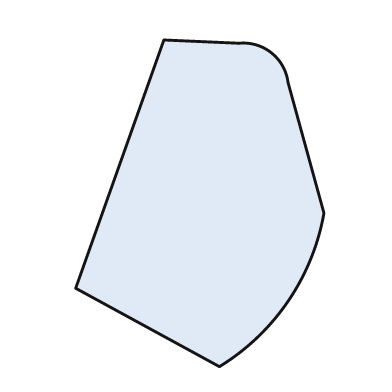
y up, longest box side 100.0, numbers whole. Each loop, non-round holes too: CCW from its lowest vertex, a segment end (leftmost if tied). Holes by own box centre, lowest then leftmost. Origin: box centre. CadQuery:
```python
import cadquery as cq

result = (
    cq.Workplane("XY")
    .moveTo(6.0, -50.0)
    .threePointArc((27.0, -30.0), (38.0, -3.0))
    .lineTo(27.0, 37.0)
    .threePointArc((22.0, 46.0), (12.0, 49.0))
    .lineTo(-11.0, 50.0)
    .lineTo(-38.0, -26.0)
    .close()
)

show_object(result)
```